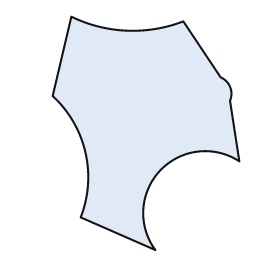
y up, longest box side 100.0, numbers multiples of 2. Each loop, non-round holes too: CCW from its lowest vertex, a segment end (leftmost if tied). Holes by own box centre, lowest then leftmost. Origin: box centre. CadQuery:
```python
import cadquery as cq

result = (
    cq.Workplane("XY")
    .moveTo(4.0, -50.0)
    .threePointArc((6.0, -16.0), (40.0, -12.0))
    .lineTo(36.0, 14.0)
    .threePointArc((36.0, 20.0), (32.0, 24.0))
    .lineTo(16.0, 48.0)
    .threePointArc((-8.0, 44.0), (-32.0, 50.0))
    .lineTo(-40.0, 16.0)
    .threePointArc((-26.0, -8.0), (-28.0, -36.0))
    .close()
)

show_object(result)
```